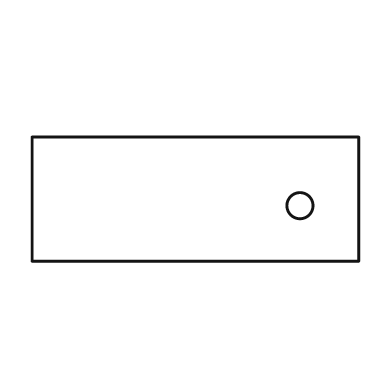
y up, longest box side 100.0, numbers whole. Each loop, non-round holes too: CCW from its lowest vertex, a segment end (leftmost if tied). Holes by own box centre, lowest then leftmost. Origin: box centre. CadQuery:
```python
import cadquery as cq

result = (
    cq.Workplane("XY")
    .moveTo(-50.0, -19.0)
    .lineTo(50.0, -19.0)
    .lineTo(50.0, 19.0)
    .lineTo(-50.0, 19.0)
    .close()
    .moveTo(32.0, -2.0)
    .circle(4.0)
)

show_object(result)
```